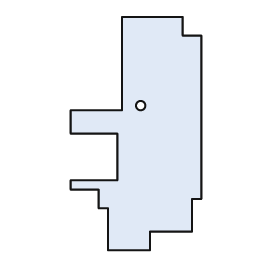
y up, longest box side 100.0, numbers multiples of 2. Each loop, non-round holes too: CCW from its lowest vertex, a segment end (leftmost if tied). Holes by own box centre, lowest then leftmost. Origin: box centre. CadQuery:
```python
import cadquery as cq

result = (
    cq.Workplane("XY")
    .moveTo(-12.0, -50.0)
    .lineTo(6.0, -50.0)
    .lineTo(6.0, -42.0)
    .lineTo(24.0, -42.0)
    .lineTo(24.0, -28.0)
    .lineTo(28.0, -28.0)
    .lineTo(28.0, 42.0)
    .lineTo(20.0, 42.0)
    .lineTo(20.0, 50.0)
    .lineTo(-6.0, 50.0)
    .lineTo(-6.0, 10.0)
    .lineTo(-28.0, 10.0)
    .lineTo(-28.0, 0.0)
    .lineTo(-8.0, 0.0)
    .lineTo(-8.0, -20.0)
    .lineTo(-28.0, -20.0)
    .lineTo(-28.0, -24.0)
    .lineTo(-16.0, -24.0)
    .lineTo(-16.0, -32.0)
    .lineTo(-12.0, -32.0)
    .close()
    .moveTo(2.0, 12.0)
    .circle(2.0)
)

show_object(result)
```